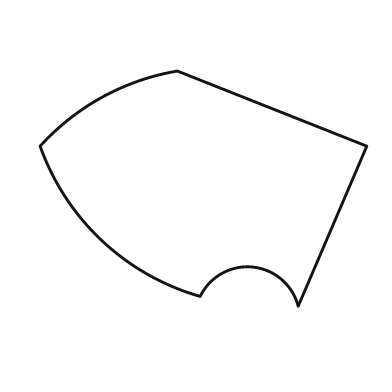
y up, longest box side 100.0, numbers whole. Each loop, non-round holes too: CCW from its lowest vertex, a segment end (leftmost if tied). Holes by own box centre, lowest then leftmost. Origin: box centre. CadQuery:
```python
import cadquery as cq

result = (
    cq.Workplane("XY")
    .moveTo(29.0, -36.0)
    .lineTo(50.0, 13.0)
    .lineTo(-8.0, 36.0)
    .threePointArc((-31.0, 28.0), (-50.0, 13.0))
    .threePointArc((-31.0, -16.0), (-1.0, -33.0))
    .threePointArc((15.0, -24.0), (29.0, -36.0))
    .close()
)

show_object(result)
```